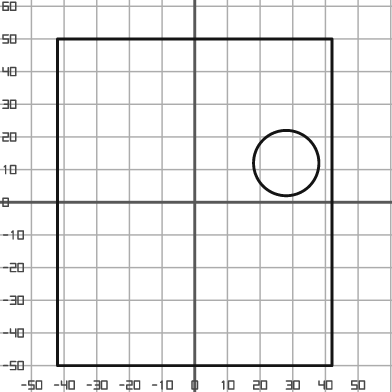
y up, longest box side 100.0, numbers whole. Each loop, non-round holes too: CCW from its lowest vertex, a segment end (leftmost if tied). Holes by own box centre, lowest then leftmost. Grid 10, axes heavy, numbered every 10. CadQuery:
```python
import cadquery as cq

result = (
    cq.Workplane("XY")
    .moveTo(-42.0, -50.0)
    .lineTo(42.0, -50.0)
    .lineTo(42.0, 50.0)
    .lineTo(-42.0, 50.0)
    .close()
    .moveTo(28.0, 12.0)
    .circle(10.0)
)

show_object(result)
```